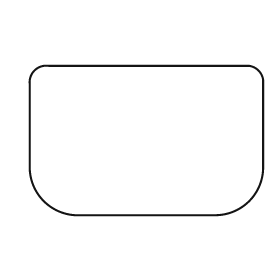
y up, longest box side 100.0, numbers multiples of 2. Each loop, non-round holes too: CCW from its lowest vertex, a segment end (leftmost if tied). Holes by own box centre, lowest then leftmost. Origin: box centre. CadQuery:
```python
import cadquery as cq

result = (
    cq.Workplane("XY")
    .moveTo(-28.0, -32.0)
    .lineTo(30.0, -32.0)
    .threePointArc((44.0, -26.0), (50.0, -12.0))
    .lineTo(50.0, 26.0)
    .threePointArc((48.0, 30.0), (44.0, 32.0))
    .lineTo(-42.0, 32.0)
    .threePointArc((-48.0, 30.0), (-50.0, 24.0))
    .lineTo(-50.0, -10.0)
    .threePointArc((-44.0, -26.0), (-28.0, -32.0))
    .close()
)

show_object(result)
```